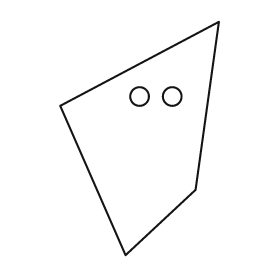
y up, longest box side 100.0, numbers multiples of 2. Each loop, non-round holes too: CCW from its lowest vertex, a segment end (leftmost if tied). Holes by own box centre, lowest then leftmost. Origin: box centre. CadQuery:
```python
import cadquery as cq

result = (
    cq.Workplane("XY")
    .moveTo(-6.0, -50.0)
    .lineTo(24.0, -22.0)
    .lineTo(34.0, 50.0)
    .lineTo(-34.0, 14.0)
    .close()
    .moveTo(0.0, 18.0)
    .circle(4.0)
    .moveTo(14.0, 18.0)
    .circle(4.0)
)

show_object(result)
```